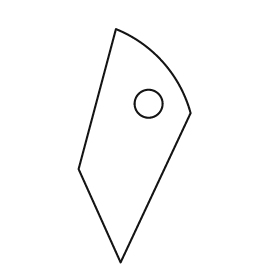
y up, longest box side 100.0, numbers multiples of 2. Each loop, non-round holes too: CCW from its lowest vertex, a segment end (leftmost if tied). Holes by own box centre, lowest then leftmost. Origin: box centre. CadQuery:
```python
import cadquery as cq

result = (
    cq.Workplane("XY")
    .moveTo(-6.0, -50.0)
    .lineTo(24.0, 14.0)
    .threePointArc((12.0, 36.0), (-8.0, 50.0))
    .lineTo(-24.0, -10.0)
    .close()
    .moveTo(6.0, 18.0)
    .circle(6.0)
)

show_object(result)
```